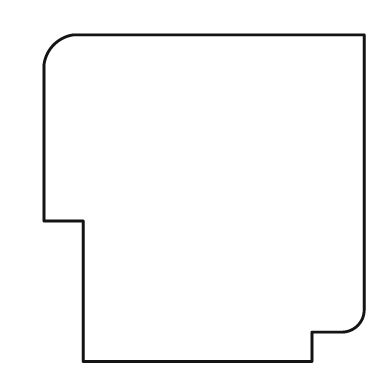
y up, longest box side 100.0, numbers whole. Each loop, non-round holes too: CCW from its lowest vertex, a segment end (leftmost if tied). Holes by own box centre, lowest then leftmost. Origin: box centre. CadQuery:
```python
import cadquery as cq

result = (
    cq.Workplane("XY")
    .moveTo(-37.0, -50.0)
    .lineTo(33.0, -50.0)
    .lineTo(33.0, -41.0)
    .lineTo(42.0, -41.0)
    .threePointArc((47.0, -39.0), (49.0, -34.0))
    .lineTo(49.0, 50.0)
    .lineTo(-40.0, 50.0)
    .threePointArc((-46.0, 47.0), (-49.0, 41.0))
    .lineTo(-49.0, -7.0)
    .lineTo(-37.0, -7.0)
    .close()
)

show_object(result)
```